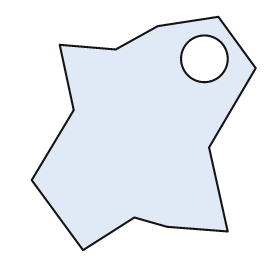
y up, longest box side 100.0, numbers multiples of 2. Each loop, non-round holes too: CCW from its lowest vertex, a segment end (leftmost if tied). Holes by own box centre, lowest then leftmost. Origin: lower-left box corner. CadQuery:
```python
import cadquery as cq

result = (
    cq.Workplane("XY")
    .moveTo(22.0, 0.0)
    .lineTo(44.0, 14.0)
    .lineTo(58.0, 10.0)
    .lineTo(84.0, 8.0)
    .lineTo(76.0, 44.0)
    .lineTo(96.0, 78.0)
    .lineTo(80.0, 100.0)
    .lineTo(54.0, 96.0)
    .lineTo(36.0, 86.0)
    .lineTo(12.0, 88.0)
    .lineTo(18.0, 60.0)
    .lineTo(0.0, 30.0)
    .close()
    .moveTo(74.0, 82.0)
    .circle(10.0)
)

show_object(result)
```